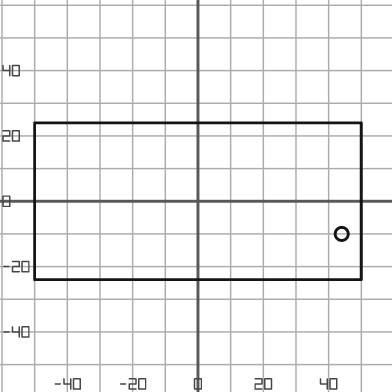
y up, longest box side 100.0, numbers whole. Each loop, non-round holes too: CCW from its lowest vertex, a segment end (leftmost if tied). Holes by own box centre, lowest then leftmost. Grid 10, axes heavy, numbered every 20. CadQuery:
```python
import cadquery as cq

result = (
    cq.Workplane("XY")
    .moveTo(-50.0, -24.0)
    .lineTo(50.0, -24.0)
    .lineTo(50.0, 24.0)
    .lineTo(-50.0, 24.0)
    .close()
    .moveTo(44.0, -10.0)
    .circle(2.0)
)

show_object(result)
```